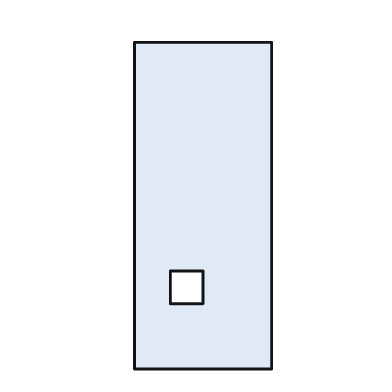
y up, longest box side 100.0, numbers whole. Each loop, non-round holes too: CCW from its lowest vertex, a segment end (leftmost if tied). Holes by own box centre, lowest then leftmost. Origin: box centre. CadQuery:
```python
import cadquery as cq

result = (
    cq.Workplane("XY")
    .moveTo(-21.0, -50.0)
    .lineTo(21.0, -50.0)
    .lineTo(21.0, 50.0)
    .lineTo(-21.0, 50.0)
    .close()
    .moveTo(-10.0, -30.0)
    .lineTo(0.0, -30.0)
    .lineTo(0.0, -20.0)
    .lineTo(-10.0, -20.0)
    .close()
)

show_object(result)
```